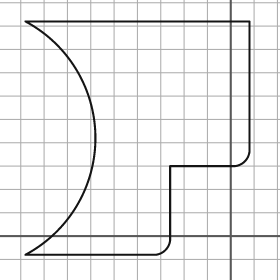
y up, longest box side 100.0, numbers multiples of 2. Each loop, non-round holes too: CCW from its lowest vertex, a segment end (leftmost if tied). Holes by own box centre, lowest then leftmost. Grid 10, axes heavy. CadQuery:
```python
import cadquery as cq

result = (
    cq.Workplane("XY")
    .moveTo(-88.0, -8.0)
    .lineTo(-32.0, -8.0)
    .threePointArc((-28.0, -6.0), (-26.0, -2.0))
    .lineTo(-26.0, 30.0)
    .lineTo(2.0, 30.0)
    .threePointArc((6.0, 32.0), (8.0, 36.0))
    .lineTo(8.0, 92.0)
    .lineTo(-88.0, 92.0)
    .threePointArc((-58.0, 42.0), (-88.0, -8.0))
    .close()
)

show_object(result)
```